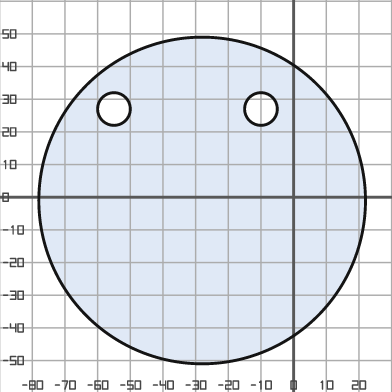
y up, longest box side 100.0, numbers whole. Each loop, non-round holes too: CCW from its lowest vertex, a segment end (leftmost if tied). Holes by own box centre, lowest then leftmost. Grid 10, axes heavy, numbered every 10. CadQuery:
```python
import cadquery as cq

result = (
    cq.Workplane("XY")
    .moveTo(-28.0, -1.0)
    .circle(50.0)
    .moveTo(-55.0, 27.0)
    .circle(5.0)
    .moveTo(-10.0, 27.0)
    .circle(5.0)
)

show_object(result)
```